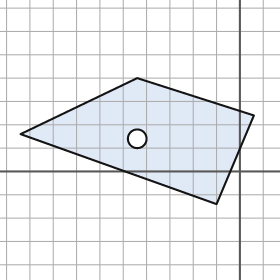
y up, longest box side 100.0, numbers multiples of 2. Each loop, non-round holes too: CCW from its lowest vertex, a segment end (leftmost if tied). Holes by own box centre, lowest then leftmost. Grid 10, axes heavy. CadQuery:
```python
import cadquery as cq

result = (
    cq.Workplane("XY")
    .moveTo(-10.0, -14.0)
    .lineTo(6.0, 24.0)
    .lineTo(-44.0, 40.0)
    .lineTo(-94.0, 16.0)
    .close()
    .moveTo(-44.0, 14.0)
    .circle(4.0)
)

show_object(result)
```